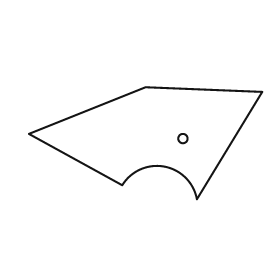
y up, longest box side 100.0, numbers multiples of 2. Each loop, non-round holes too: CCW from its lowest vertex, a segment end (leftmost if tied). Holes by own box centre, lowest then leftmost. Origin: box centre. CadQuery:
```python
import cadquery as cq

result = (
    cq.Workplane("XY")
    .moveTo(22.0, -24.0)
    .lineTo(50.0, 22.0)
    .lineTo(0.0, 24.0)
    .lineTo(-50.0, 4.0)
    .lineTo(-10.0, -18.0)
    .threePointArc((8.0, -10.0), (22.0, -24.0))
    .close()
    .moveTo(16.0, 2.0)
    .circle(2.0)
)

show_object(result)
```